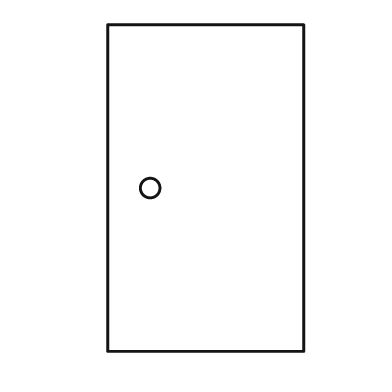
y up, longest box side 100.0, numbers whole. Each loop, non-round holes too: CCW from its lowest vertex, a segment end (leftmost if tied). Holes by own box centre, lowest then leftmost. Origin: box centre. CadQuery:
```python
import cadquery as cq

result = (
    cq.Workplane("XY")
    .moveTo(-30.0, -50.0)
    .lineTo(30.0, -50.0)
    .lineTo(30.0, 50.0)
    .lineTo(-30.0, 50.0)
    .close()
    .moveTo(-17.0, 0.0)
    .circle(3.0)
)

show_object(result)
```